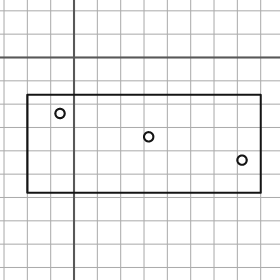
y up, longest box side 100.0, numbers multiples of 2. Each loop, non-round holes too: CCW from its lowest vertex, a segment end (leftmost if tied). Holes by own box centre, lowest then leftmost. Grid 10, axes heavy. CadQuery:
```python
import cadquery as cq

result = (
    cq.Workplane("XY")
    .moveTo(-20.0, -58.0)
    .lineTo(80.0, -58.0)
    .lineTo(80.0, -16.0)
    .lineTo(-20.0, -16.0)
    .close()
    .moveTo(72.0, -44.0)
    .circle(2.0)
    .moveTo(32.0, -34.0)
    .circle(2.0)
    .moveTo(-6.0, -24.0)
    .circle(2.0)
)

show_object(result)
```